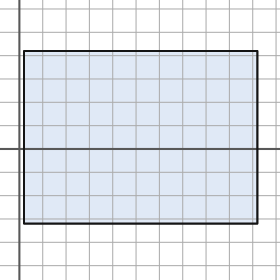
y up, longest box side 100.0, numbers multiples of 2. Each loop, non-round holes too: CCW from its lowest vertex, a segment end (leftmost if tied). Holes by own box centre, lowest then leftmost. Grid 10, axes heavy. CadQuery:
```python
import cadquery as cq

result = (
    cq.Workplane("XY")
    .moveTo(2.0, -32.0)
    .lineTo(102.0, -32.0)
    .lineTo(102.0, 42.0)
    .lineTo(2.0, 42.0)
    .close()
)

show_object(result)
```